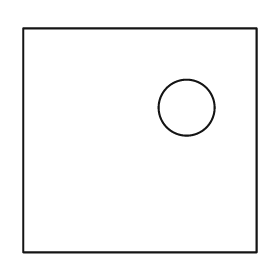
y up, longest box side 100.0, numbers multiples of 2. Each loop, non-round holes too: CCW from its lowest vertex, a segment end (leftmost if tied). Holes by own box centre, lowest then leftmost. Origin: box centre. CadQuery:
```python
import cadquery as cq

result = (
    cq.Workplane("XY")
    .moveTo(-50.0, -48.0)
    .lineTo(50.0, -48.0)
    .lineTo(50.0, 48.0)
    .lineTo(-50.0, 48.0)
    .close()
    .moveTo(20.0, 14.0)
    .circle(12.0)
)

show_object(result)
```